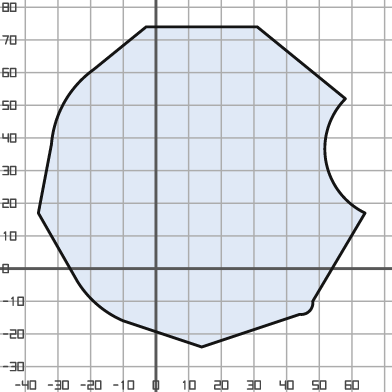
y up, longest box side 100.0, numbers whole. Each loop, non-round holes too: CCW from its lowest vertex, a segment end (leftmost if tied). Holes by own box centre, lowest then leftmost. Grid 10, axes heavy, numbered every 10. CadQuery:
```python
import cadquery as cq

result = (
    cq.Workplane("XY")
    .moveTo(14.0, -24.0)
    .lineTo(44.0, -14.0)
    .threePointArc((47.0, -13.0), (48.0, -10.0))
    .lineTo(64.0, 17.0)
    .threePointArc((52.0, 33.0), (58.0, 52.0))
    .lineTo(31.0, 74.0)
    .lineTo(-3.0, 74.0)
    .lineTo(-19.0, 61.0)
    .threePointArc((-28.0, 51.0), (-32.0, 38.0))
    .lineTo(-36.0, 17.0)
    .lineTo(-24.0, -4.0)
    .threePointArc((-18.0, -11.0), (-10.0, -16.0))
    .close()
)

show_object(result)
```